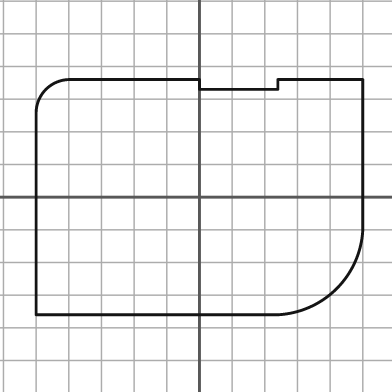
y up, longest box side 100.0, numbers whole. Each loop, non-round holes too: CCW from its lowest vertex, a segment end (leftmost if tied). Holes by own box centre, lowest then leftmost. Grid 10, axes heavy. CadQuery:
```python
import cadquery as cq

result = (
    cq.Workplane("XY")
    .moveTo(-50.0, -36.0)
    .lineTo(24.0, -36.0)
    .threePointArc((42.0, -28.0), (50.0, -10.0))
    .lineTo(50.0, 36.0)
    .lineTo(24.0, 36.0)
    .lineTo(24.0, 33.0)
    .lineTo(0.0, 33.0)
    .lineTo(0.0, 36.0)
    .lineTo(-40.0, 36.0)
    .threePointArc((-47.0, 33.0), (-50.0, 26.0))
    .close()
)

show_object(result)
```